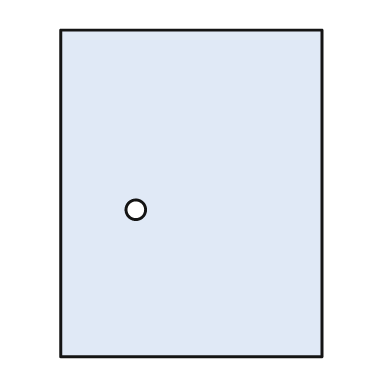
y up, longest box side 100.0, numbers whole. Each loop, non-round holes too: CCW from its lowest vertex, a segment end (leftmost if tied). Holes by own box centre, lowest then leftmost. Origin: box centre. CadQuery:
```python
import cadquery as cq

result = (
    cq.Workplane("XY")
    .moveTo(-40.0, -50.0)
    .lineTo(40.0, -50.0)
    .lineTo(40.0, 50.0)
    .lineTo(-40.0, 50.0)
    .close()
    .moveTo(-17.0, -5.0)
    .circle(3.0)
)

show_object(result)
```